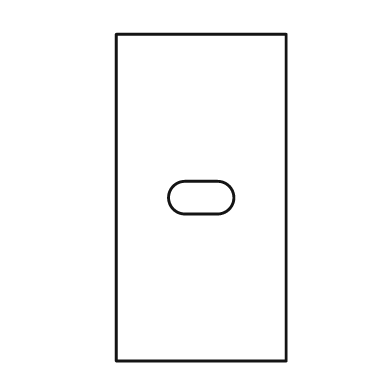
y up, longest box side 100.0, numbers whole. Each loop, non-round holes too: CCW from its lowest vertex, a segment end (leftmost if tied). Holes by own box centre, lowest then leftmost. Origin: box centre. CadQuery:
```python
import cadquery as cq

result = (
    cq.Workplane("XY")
    .moveTo(-26.0, -50.0)
    .lineTo(26.0, -50.0)
    .lineTo(26.0, 50.0)
    .lineTo(-26.0, 50.0)
    .close()
    .moveTo(-5.0, -5.0)
    .lineTo(5.0, -5.0)
    .threePointArc((10.0, 0.0), (5.0, 5.0))
    .lineTo(-5.0, 5.0)
    .threePointArc((-10.0, 0.0), (-5.0, -5.0))
    .close()
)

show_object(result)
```